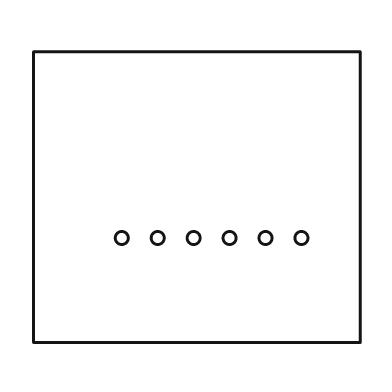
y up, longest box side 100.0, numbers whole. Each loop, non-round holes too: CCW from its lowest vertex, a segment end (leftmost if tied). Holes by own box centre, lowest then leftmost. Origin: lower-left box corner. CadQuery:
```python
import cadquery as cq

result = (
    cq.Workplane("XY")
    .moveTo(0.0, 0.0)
    .lineTo(100.0, 0.0)
    .lineTo(100.0, 89.0)
    .lineTo(0.0, 89.0)
    .close()
    .moveTo(27.0, 32.0)
    .circle(2.0)
    .moveTo(38.0, 32.0)
    .circle(2.0)
    .moveTo(49.0, 32.0)
    .circle(2.0)
    .moveTo(60.0, 32.0)
    .circle(2.0)
    .moveTo(71.0, 32.0)
    .circle(2.0)
    .moveTo(82.0, 32.0)
    .circle(2.0)
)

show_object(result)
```